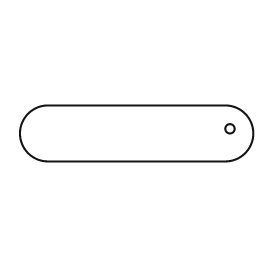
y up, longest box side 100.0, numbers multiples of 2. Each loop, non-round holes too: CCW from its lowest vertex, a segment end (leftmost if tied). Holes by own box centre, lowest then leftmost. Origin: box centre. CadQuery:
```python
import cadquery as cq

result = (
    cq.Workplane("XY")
    .moveTo(-38.0, -12.0)
    .lineTo(38.0, -12.0)
    .threePointArc((50.0, 0.0), (38.0, 12.0))
    .lineTo(-38.0, 12.0)
    .threePointArc((-50.0, 0.0), (-38.0, -12.0))
    .close()
    .moveTo(40.0, 2.0)
    .circle(2.0)
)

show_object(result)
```